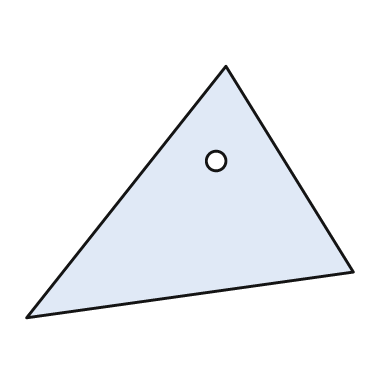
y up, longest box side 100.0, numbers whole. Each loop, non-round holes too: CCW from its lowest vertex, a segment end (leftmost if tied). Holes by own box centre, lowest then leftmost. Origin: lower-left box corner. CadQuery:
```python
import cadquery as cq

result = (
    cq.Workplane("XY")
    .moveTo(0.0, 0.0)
    .lineTo(100.0, 14.0)
    .lineTo(61.0, 77.0)
    .close()
    .moveTo(58.0, 48.0)
    .circle(3.0)
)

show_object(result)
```